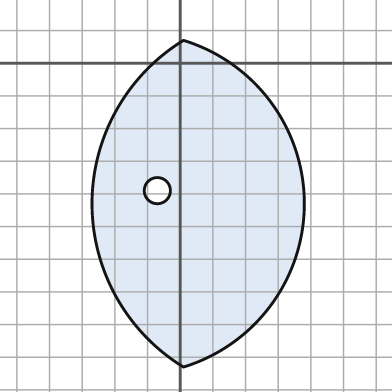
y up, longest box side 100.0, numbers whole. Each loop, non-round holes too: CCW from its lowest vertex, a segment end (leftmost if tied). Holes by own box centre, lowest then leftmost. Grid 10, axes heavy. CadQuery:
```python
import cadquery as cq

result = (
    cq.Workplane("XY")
    .moveTo(1.0, -93.0)
    .threePointArc((38.0, -43.0), (1.0, 7.0))
    .threePointArc((-27.0, -43.0), (1.0, -93.0))
    .close()
    .moveTo(-7.0, -39.0)
    .circle(4.0)
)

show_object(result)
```